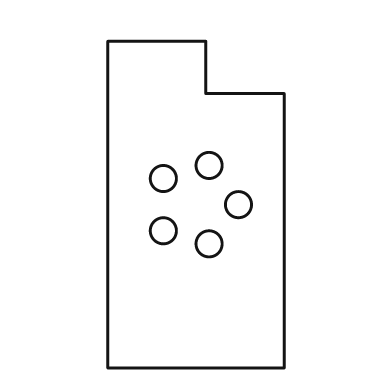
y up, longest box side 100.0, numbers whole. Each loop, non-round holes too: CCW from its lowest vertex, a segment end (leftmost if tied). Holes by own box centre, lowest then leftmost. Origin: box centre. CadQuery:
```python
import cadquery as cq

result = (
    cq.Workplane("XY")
    .moveTo(-27.0, -50.0)
    .lineTo(27.0, -50.0)
    .lineTo(27.0, 34.0)
    .lineTo(3.0, 34.0)
    .lineTo(3.0, 50.0)
    .lineTo(-27.0, 50.0)
    .close()
    .moveTo(4.0, -12.0)
    .circle(4.0)
    .moveTo(-10.0, -8.0)
    .circle(4.0)
    .moveTo(13.0, 0.0)
    .circle(4.0)
    .moveTo(-10.0, 8.0)
    .circle(4.0)
    .moveTo(4.0, 12.0)
    .circle(4.0)
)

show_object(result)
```